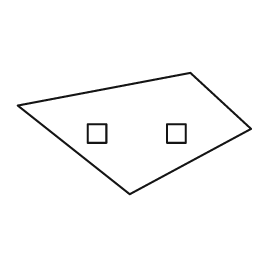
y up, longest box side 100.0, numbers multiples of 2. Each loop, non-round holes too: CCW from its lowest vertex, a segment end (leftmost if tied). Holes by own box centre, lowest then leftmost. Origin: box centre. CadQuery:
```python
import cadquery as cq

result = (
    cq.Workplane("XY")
    .moveTo(-2.0, -26.0)
    .lineTo(50.0, 2.0)
    .lineTo(24.0, 26.0)
    .lineTo(-50.0, 12.0)
    .close()
    .moveTo(-20.0, -4.0)
    .lineTo(-12.0, -4.0)
    .lineTo(-12.0, 4.0)
    .lineTo(-20.0, 4.0)
    .close()
    .moveTo(14.0, -4.0)
    .lineTo(22.0, -4.0)
    .lineTo(22.0, 4.0)
    .lineTo(14.0, 4.0)
    .close()
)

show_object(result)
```